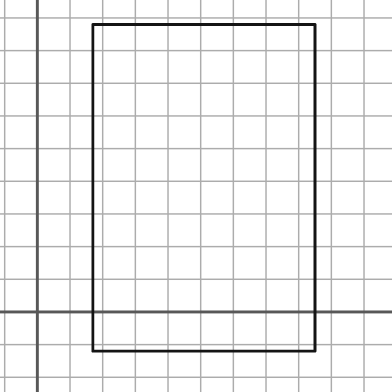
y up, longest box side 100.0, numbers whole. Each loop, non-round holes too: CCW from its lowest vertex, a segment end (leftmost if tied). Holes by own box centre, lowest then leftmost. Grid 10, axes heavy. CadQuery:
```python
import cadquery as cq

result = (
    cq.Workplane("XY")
    .moveTo(17.0, -12.0)
    .lineTo(85.0, -12.0)
    .lineTo(85.0, 88.0)
    .lineTo(17.0, 88.0)
    .close()
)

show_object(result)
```